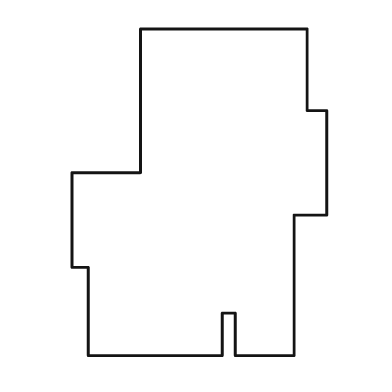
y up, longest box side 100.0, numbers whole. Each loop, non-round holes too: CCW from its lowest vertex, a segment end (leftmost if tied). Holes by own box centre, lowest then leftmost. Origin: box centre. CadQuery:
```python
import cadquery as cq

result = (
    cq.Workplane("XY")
    .moveTo(-34.0, -50.0)
    .lineTo(7.0, -50.0)
    .lineTo(7.0, -37.0)
    .lineTo(11.0, -37.0)
    .lineTo(11.0, -50.0)
    .lineTo(29.0, -50.0)
    .lineTo(29.0, -7.0)
    .lineTo(39.0, -7.0)
    .lineTo(39.0, 25.0)
    .lineTo(33.0, 25.0)
    .lineTo(33.0, 50.0)
    .lineTo(-18.0, 50.0)
    .lineTo(-18.0, 6.0)
    .lineTo(-39.0, 6.0)
    .lineTo(-39.0, -23.0)
    .lineTo(-34.0, -23.0)
    .close()
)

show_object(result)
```